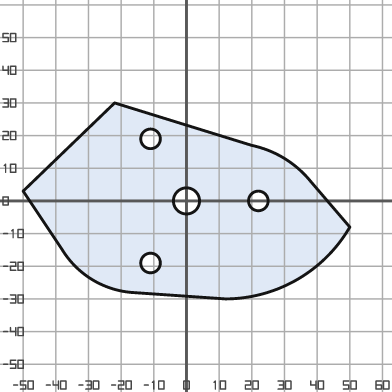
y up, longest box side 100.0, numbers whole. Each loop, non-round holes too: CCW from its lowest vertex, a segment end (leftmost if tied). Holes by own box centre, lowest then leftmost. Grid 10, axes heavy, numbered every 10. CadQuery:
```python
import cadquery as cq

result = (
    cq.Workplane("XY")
    .moveTo(12.0, -30.0)
    .threePointArc((34.0, -24.0), (50.0, -8.0))
    .lineTo(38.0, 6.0)
    .threePointArc((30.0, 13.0), (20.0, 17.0))
    .lineTo(-22.0, 30.0)
    .lineTo(-50.0, 3.0)
    .lineTo(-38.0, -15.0)
    .threePointArc((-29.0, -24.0), (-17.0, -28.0))
    .close()
    .moveTo(-11.0, -19.0)
    .circle(3.0)
    .moveTo(0.0, 0.0)
    .circle(4.0)
    .moveTo(22.0, 0.0)
    .circle(3.0)
    .moveTo(-11.0, 19.0)
    .circle(3.0)
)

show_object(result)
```